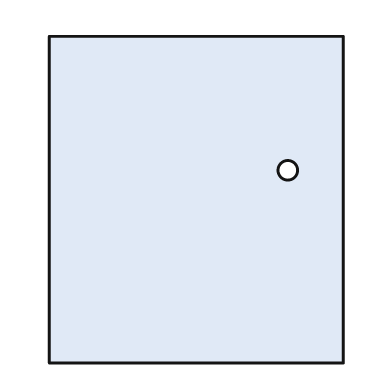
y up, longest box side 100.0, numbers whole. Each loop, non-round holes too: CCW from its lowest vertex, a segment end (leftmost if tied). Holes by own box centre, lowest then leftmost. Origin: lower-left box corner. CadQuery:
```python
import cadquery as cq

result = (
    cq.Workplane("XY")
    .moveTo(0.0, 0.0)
    .lineTo(90.0, 0.0)
    .lineTo(90.0, 100.0)
    .lineTo(0.0, 100.0)
    .close()
    .moveTo(73.0, 59.0)
    .circle(3.0)
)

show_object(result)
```